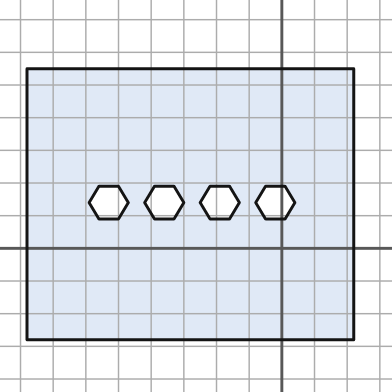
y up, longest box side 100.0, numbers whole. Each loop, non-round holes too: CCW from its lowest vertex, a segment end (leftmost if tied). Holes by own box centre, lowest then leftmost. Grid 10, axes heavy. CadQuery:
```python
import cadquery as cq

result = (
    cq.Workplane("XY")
    .moveTo(-78.0, -28.0)
    .lineTo(22.0, -28.0)
    .lineTo(22.0, 55.0)
    .lineTo(-78.0, 55.0)
    .close()
    .moveTo(-56.0, 9.0)
    .lineTo(-50.0, 9.0)
    .lineTo(-47.0, 14.0)
    .lineTo(-50.0, 19.0)
    .lineTo(-56.0, 19.0)
    .lineTo(-59.0, 14.0)
    .close()
    .moveTo(-39.0, 9.0)
    .lineTo(-33.0, 9.0)
    .lineTo(-30.0, 14.0)
    .lineTo(-33.0, 19.0)
    .lineTo(-39.0, 19.0)
    .lineTo(-42.0, 14.0)
    .close()
    .moveTo(-22.0, 9.0)
    .lineTo(-16.0, 9.0)
    .lineTo(-13.0, 14.0)
    .lineTo(-16.0, 19.0)
    .lineTo(-22.0, 19.0)
    .lineTo(-25.0, 14.0)
    .close()
    .moveTo(-5.0, 9.0)
    .lineTo(1.0, 9.0)
    .lineTo(4.0, 14.0)
    .lineTo(1.0, 19.0)
    .lineTo(-5.0, 19.0)
    .lineTo(-8.0, 14.0)
    .close()
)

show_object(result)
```